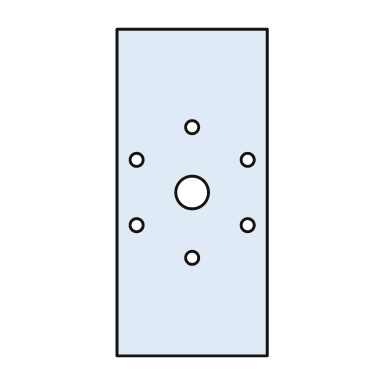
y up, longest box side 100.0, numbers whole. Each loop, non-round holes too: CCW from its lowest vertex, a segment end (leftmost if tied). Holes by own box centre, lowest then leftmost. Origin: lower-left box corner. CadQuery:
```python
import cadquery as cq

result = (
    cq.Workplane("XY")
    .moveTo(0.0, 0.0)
    .lineTo(46.0, 0.0)
    .lineTo(46.0, 100.0)
    .lineTo(0.0, 100.0)
    .close()
    .moveTo(23.0, 30.0)
    .circle(2.0)
    .moveTo(6.0, 40.0)
    .circle(2.0)
    .moveTo(40.0, 40.0)
    .circle(2.0)
    .moveTo(23.0, 50.0)
    .circle(5.0)
    .moveTo(6.0, 60.0)
    .circle(2.0)
    .moveTo(40.0, 60.0)
    .circle(2.0)
    .moveTo(23.0, 70.0)
    .circle(2.0)
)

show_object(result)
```